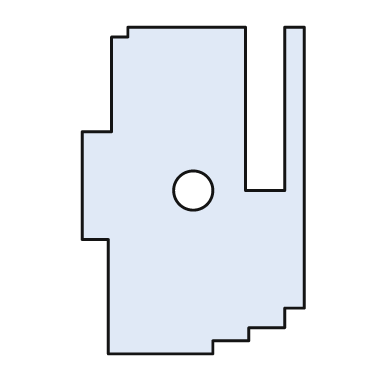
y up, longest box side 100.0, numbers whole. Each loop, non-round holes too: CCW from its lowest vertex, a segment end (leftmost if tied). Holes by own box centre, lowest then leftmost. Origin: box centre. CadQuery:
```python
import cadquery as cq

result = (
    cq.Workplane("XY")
    .moveTo(-26.0, -50.0)
    .lineTo(6.0, -50.0)
    .lineTo(6.0, -46.0)
    .lineTo(17.0, -46.0)
    .lineTo(17.0, -42.0)
    .lineTo(28.0, -42.0)
    .lineTo(28.0, -36.0)
    .lineTo(34.0, -36.0)
    .lineTo(34.0, 50.0)
    .lineTo(28.0, 50.0)
    .lineTo(28.0, 0.0)
    .lineTo(16.0, 0.0)
    .lineTo(16.0, 50.0)
    .lineTo(-20.0, 50.0)
    .lineTo(-20.0, 47.0)
    .lineTo(-25.0, 47.0)
    .lineTo(-25.0, 18.0)
    .lineTo(-34.0, 18.0)
    .lineTo(-34.0, -15.0)
    .lineTo(-26.0, -15.0)
    .close()
    .moveTo(0.0, 0.0)
    .circle(6.0)
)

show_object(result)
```